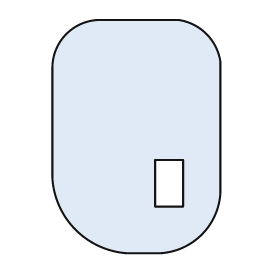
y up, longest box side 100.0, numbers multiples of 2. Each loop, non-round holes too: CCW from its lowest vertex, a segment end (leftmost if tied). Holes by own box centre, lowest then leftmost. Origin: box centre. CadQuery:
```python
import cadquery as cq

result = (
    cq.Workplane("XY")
    .moveTo(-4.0, -50.0)
    .lineTo(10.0, -50.0)
    .threePointArc((28.0, -42.0), (36.0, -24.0))
    .lineTo(36.0, 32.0)
    .threePointArc((30.0, 44.0), (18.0, 50.0))
    .lineTo(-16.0, 50.0)
    .threePointArc((-30.0, 44.0), (-36.0, 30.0))
    .lineTo(-36.0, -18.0)
    .threePointArc((-26.0, -40.0), (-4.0, -50.0))
    .close()
    .moveTo(8.0, -30.0)
    .lineTo(20.0, -30.0)
    .lineTo(20.0, -10.0)
    .lineTo(8.0, -10.0)
    .close()
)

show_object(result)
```